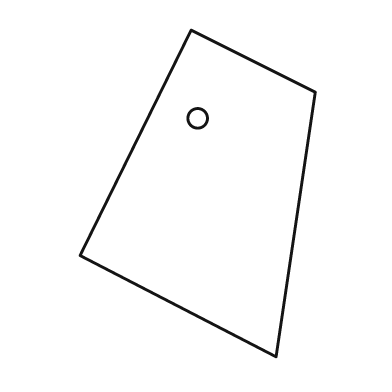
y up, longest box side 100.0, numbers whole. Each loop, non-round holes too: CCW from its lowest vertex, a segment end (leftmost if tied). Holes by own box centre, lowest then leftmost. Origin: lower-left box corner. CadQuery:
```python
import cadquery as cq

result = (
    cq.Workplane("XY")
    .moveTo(60.0, 0.0)
    .lineTo(72.0, 81.0)
    .lineTo(34.0, 100.0)
    .lineTo(0.0, 31.0)
    .close()
    .moveTo(36.0, 73.0)
    .circle(3.0)
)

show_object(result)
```